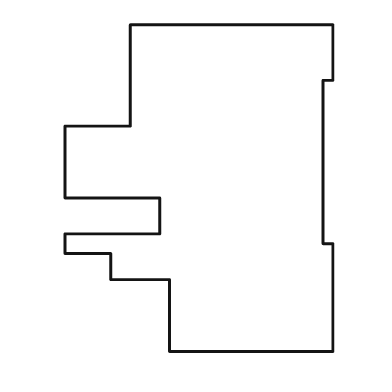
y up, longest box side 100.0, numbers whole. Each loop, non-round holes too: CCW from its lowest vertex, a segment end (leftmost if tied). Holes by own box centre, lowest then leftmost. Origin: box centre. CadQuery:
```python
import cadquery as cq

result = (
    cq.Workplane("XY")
    .moveTo(-9.0, -50.0)
    .lineTo(41.0, -50.0)
    .lineTo(41.0, -17.0)
    .lineTo(38.0, -17.0)
    .lineTo(38.0, 33.0)
    .lineTo(41.0, 33.0)
    .lineTo(41.0, 50.0)
    .lineTo(-21.0, 50.0)
    .lineTo(-21.0, 19.0)
    .lineTo(-41.0, 19.0)
    .lineTo(-41.0, -3.0)
    .lineTo(-12.0, -3.0)
    .lineTo(-12.0, -14.0)
    .lineTo(-41.0, -14.0)
    .lineTo(-41.0, -20.0)
    .lineTo(-27.0, -20.0)
    .lineTo(-27.0, -28.0)
    .lineTo(-9.0, -28.0)
    .close()
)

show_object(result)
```